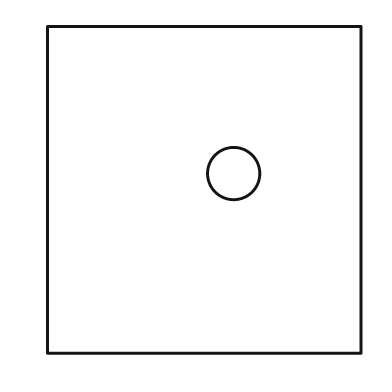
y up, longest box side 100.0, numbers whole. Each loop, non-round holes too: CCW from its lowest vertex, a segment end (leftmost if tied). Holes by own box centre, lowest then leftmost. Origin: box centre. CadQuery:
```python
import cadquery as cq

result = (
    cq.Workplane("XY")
    .moveTo(-48.0, -50.0)
    .lineTo(48.0, -50.0)
    .lineTo(48.0, 50.0)
    .lineTo(-48.0, 50.0)
    .close()
    .moveTo(9.0, 5.0)
    .circle(8.0)
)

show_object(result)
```